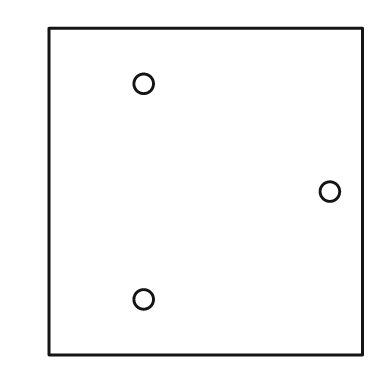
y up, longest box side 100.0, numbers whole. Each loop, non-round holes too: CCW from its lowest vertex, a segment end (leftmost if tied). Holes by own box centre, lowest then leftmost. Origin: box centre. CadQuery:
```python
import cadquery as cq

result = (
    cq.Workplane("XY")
    .moveTo(-48.0, -50.0)
    .lineTo(48.0, -50.0)
    .lineTo(48.0, 50.0)
    .lineTo(-48.0, 50.0)
    .close()
    .moveTo(-19.0, -33.0)
    .circle(3.0)
    .moveTo(38.0, 0.0)
    .circle(3.0)
    .moveTo(-19.0, 33.0)
    .circle(3.0)
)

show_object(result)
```